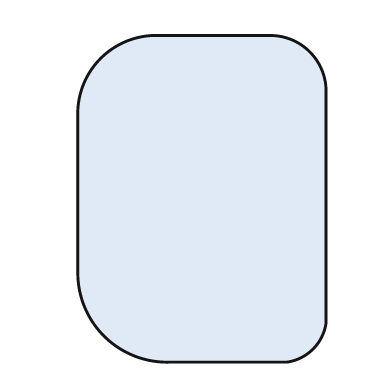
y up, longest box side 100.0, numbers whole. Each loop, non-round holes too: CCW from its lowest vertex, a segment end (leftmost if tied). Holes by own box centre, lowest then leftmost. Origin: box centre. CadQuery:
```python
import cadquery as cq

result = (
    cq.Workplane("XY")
    .moveTo(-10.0, -50.0)
    .lineTo(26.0, -50.0)
    .threePointArc((34.0, -46.0), (38.0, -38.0))
    .lineTo(38.0, 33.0)
    .threePointArc((33.0, 45.0), (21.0, 50.0))
    .lineTo(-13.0, 50.0)
    .threePointArc((-31.0, 43.0), (-38.0, 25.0))
    .lineTo(-38.0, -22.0)
    .threePointArc((-30.0, -42.0), (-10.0, -50.0))
    .close()
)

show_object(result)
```